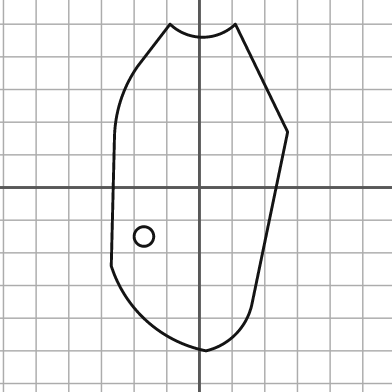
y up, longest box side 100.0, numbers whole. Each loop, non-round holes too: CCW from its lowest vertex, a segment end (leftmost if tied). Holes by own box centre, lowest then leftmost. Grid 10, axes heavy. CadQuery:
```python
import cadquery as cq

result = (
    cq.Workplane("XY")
    .moveTo(2.0, -50.0)
    .threePointArc((11.0, -45.0), (16.0, -36.0))
    .lineTo(27.0, 17.0)
    .lineTo(11.0, 50.0)
    .threePointArc((1.0, 46.0), (-9.0, 50.0))
    .lineTo(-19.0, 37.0)
    .threePointArc((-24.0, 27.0), (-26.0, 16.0))
    .lineTo(-27.0, -24.0)
    .threePointArc((-16.0, -41.0), (2.0, -50.0))
    .close()
    .moveTo(-17.0, -15.0)
    .circle(3.0)
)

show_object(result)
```